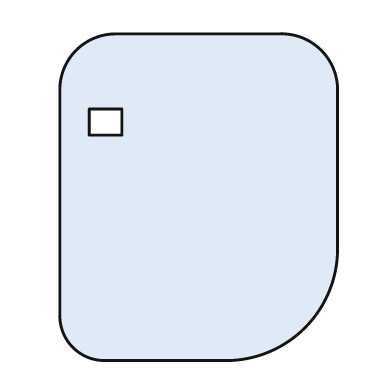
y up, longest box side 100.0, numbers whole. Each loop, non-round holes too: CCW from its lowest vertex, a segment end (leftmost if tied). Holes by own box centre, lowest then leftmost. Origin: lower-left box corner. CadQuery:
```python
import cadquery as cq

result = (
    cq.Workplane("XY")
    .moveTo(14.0, 0.0)
    .lineTo(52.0, 0.0)
    .threePointArc((75.0, 10.0), (85.0, 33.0))
    .lineTo(85.0, 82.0)
    .threePointArc((80.0, 95.0), (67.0, 100.0))
    .lineTo(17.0, 100.0)
    .threePointArc((5.0, 95.0), (0.0, 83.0))
    .lineTo(0.0, 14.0)
    .threePointArc((4.0, 4.0), (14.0, 0.0))
    .close()
    .moveTo(9.0, 69.0)
    .lineTo(19.0, 69.0)
    .lineTo(19.0, 77.0)
    .lineTo(9.0, 77.0)
    .close()
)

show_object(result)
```